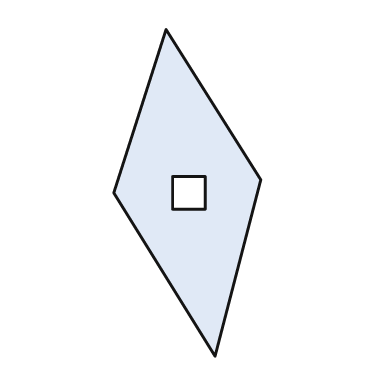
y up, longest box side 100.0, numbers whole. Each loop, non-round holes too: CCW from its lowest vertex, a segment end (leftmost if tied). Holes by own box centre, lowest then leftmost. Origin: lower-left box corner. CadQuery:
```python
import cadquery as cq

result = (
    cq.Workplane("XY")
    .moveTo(31.0, 0.0)
    .lineTo(45.0, 54.0)
    .lineTo(16.0, 100.0)
    .lineTo(0.0, 50.0)
    .close()
    .moveTo(18.0, 45.0)
    .lineTo(28.0, 45.0)
    .lineTo(28.0, 55.0)
    .lineTo(18.0, 55.0)
    .close()
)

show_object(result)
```